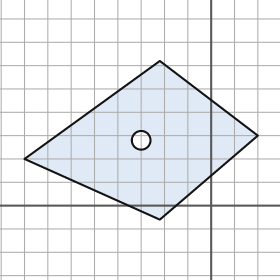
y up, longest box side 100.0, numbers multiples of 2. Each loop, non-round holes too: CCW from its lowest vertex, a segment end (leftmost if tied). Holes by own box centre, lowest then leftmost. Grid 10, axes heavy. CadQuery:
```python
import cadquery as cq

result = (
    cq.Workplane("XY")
    .moveTo(-22.0, -6.0)
    .lineTo(20.0, 30.0)
    .lineTo(-22.0, 62.0)
    .lineTo(-80.0, 20.0)
    .close()
    .moveTo(-30.0, 28.0)
    .circle(4.0)
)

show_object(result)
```